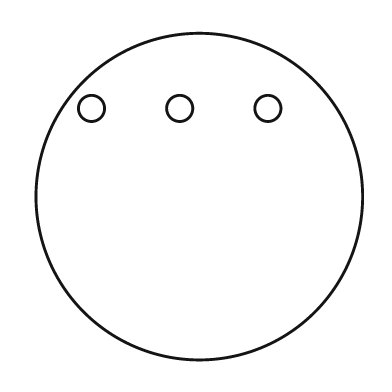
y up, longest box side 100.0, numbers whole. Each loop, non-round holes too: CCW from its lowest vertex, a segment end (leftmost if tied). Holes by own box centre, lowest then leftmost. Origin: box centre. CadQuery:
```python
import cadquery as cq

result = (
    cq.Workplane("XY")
    .moveTo(0.0, 0.0)
    .circle(50.0)
    .moveTo(-33.0, 27.0)
    .circle(4.0)
    .moveTo(-6.0, 27.0)
    .circle(4.0)
    .moveTo(21.0, 27.0)
    .circle(4.0)
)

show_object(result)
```